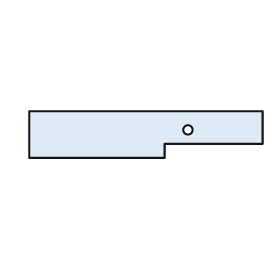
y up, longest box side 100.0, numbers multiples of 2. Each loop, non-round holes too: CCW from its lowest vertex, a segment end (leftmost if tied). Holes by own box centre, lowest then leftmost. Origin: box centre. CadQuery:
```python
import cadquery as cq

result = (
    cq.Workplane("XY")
    .moveTo(-50.0, -10.0)
    .lineTo(8.0, -10.0)
    .lineTo(8.0, -4.0)
    .lineTo(50.0, -4.0)
    .lineTo(50.0, 10.0)
    .lineTo(-50.0, 10.0)
    .close()
    .moveTo(18.0, 2.0)
    .circle(2.0)
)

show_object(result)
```